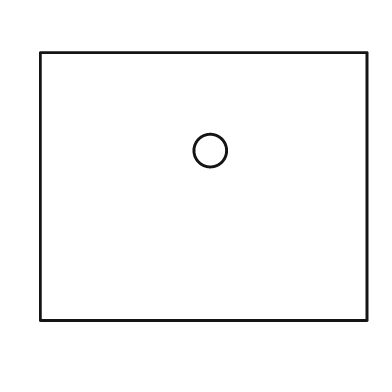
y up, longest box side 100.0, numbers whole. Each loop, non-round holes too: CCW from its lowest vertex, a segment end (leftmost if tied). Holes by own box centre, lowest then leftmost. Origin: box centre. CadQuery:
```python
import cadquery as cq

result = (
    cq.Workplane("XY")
    .moveTo(-50.0, -41.0)
    .lineTo(50.0, -41.0)
    .lineTo(50.0, 41.0)
    .lineTo(-50.0, 41.0)
    .close()
    .moveTo(2.0, 11.0)
    .circle(5.0)
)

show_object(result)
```